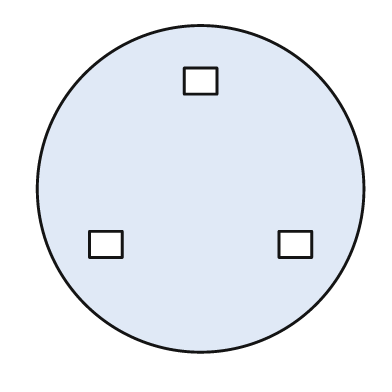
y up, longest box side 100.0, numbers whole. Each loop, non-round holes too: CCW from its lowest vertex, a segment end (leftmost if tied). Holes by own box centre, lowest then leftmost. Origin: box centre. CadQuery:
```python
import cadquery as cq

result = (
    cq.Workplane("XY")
    .moveTo(0.0, 0.0)
    .circle(50.0)
    .moveTo(-34.0, -21.0)
    .lineTo(-24.0, -21.0)
    .lineTo(-24.0, -13.0)
    .lineTo(-34.0, -13.0)
    .close()
    .moveTo(24.0, -21.0)
    .lineTo(34.0, -21.0)
    .lineTo(34.0, -13.0)
    .lineTo(24.0, -13.0)
    .close()
    .moveTo(-5.0, 29.0)
    .lineTo(5.0, 29.0)
    .lineTo(5.0, 37.0)
    .lineTo(-5.0, 37.0)
    .close()
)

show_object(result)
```